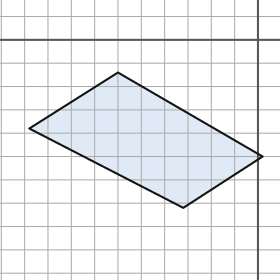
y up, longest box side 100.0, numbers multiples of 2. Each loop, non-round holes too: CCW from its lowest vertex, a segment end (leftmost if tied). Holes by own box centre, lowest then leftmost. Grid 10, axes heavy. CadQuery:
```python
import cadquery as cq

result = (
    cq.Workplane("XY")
    .moveTo(-32.0, -72.0)
    .lineTo(2.0, -50.0)
    .lineTo(-60.0, -14.0)
    .lineTo(-98.0, -38.0)
    .close()
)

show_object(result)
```